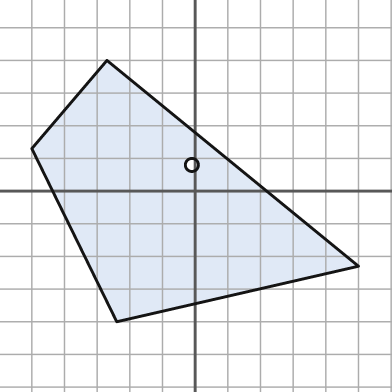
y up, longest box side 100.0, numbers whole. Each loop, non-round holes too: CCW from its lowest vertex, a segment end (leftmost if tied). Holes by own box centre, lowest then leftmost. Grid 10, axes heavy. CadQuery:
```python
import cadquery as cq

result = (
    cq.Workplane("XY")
    .moveTo(-24.0, -40.0)
    .lineTo(50.0, -23.0)
    .lineTo(-27.0, 40.0)
    .lineTo(-50.0, 13.0)
    .close()
    .moveTo(-1.0, 8.0)
    .circle(2.0)
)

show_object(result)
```